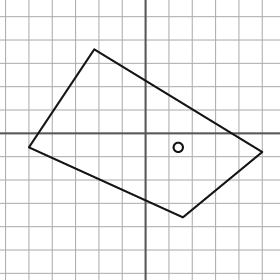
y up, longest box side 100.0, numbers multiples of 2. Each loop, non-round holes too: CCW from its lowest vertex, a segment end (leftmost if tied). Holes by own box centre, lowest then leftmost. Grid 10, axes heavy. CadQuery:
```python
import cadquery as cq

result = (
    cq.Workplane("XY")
    .moveTo(16.0, -36.0)
    .lineTo(50.0, -8.0)
    .lineTo(-22.0, 36.0)
    .lineTo(-50.0, -6.0)
    .close()
    .moveTo(14.0, -6.0)
    .circle(2.0)
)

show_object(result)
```